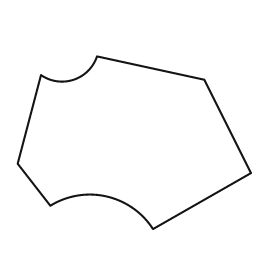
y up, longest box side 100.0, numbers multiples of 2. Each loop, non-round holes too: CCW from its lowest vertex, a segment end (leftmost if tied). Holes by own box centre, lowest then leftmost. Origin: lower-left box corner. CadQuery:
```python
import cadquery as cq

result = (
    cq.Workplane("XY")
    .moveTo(58.0, 0.0)
    .lineTo(100.0, 24.0)
    .lineTo(80.0, 64.0)
    .lineTo(34.0, 74.0)
    .threePointArc((24.0, 64.0), (10.0, 66.0))
    .lineTo(0.0, 28.0)
    .lineTo(14.0, 10.0)
    .threePointArc((38.0, 14.0), (58.0, 0.0))
    .close()
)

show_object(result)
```